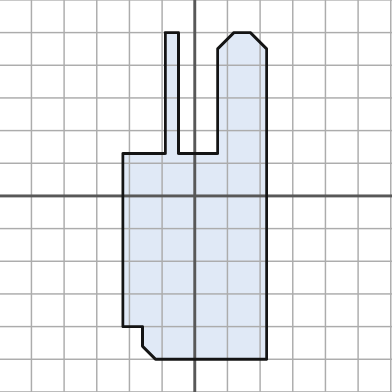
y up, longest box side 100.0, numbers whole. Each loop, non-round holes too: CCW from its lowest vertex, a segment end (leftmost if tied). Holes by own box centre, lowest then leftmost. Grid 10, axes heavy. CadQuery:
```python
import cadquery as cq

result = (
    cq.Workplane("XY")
    .moveTo(-12.0, -50.0)
    .lineTo(22.0, -50.0)
    .lineTo(22.0, 45.0)
    .lineTo(17.0, 50.0)
    .lineTo(12.0, 50.0)
    .lineTo(7.0, 45.0)
    .lineTo(7.0, 13.0)
    .lineTo(-5.0, 13.0)
    .lineTo(-5.0, 50.0)
    .lineTo(-9.0, 50.0)
    .lineTo(-9.0, 13.0)
    .lineTo(-22.0, 13.0)
    .lineTo(-22.0, -40.0)
    .lineTo(-16.0, -40.0)
    .lineTo(-16.0, -46.0)
    .close()
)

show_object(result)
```